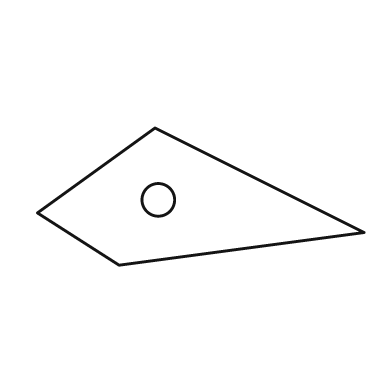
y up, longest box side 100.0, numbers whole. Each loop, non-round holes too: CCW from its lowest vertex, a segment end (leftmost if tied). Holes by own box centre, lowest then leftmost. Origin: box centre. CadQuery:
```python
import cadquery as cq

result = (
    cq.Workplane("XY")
    .moveTo(-25.0, -21.0)
    .lineTo(50.0, -11.0)
    .lineTo(-14.0, 21.0)
    .lineTo(-50.0, -5.0)
    .close()
    .moveTo(-13.0, -1.0)
    .circle(5.0)
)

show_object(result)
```